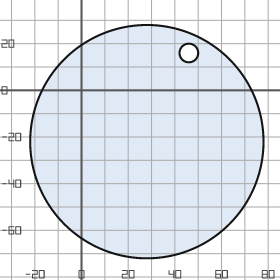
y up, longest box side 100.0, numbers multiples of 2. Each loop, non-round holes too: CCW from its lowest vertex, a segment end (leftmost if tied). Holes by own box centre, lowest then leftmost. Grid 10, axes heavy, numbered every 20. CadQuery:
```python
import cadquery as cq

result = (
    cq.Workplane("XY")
    .moveTo(28.0, -22.0)
    .circle(50.0)
    .moveTo(46.0, 16.0)
    .circle(4.0)
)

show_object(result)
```